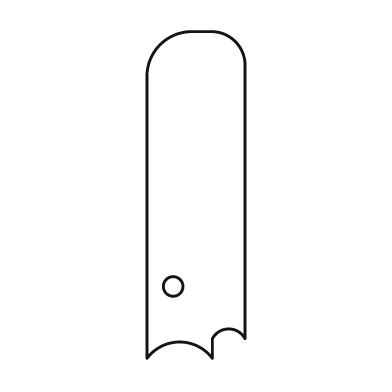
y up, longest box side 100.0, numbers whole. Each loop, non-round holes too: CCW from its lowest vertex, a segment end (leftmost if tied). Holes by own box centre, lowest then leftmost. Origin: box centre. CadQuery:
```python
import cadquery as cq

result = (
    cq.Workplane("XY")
    .moveTo(-15.0, -50.0)
    .threePointArc((-5.0, -45.0), (5.0, -50.0))
    .lineTo(5.0, -44.0)
    .threePointArc((10.0, -41.0), (15.0, -44.0))
    .lineTo(15.0, 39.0)
    .threePointArc((12.0, 47.0), (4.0, 50.0))
    .lineTo(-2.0, 50.0)
    .threePointArc((-11.0, 46.0), (-15.0, 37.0))
    .close()
    .moveTo(-7.0, -28.0)
    .circle(3.0)
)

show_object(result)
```